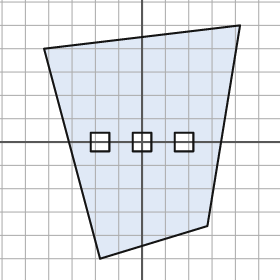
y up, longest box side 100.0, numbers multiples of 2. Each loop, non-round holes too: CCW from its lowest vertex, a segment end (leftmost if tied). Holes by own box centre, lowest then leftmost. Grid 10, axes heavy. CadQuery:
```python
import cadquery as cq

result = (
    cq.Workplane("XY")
    .moveTo(-18.0, -50.0)
    .lineTo(28.0, -36.0)
    .lineTo(42.0, 50.0)
    .lineTo(-42.0, 40.0)
    .close()
    .moveTo(-22.0, -4.0)
    .lineTo(-14.0, -4.0)
    .lineTo(-14.0, 4.0)
    .lineTo(-22.0, 4.0)
    .close()
    .moveTo(-4.0, -4.0)
    .lineTo(4.0, -4.0)
    .lineTo(4.0, 4.0)
    .lineTo(-4.0, 4.0)
    .close()
    .moveTo(14.0, -4.0)
    .lineTo(22.0, -4.0)
    .lineTo(22.0, 4.0)
    .lineTo(14.0, 4.0)
    .close()
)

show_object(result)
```